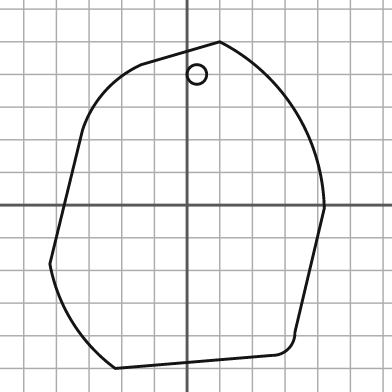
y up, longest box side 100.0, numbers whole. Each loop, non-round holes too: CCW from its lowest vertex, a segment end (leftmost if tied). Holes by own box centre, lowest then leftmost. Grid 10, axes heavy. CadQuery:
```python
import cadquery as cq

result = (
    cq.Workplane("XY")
    .moveTo(-22.0, -50.0)
    .lineTo(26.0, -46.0)
    .threePointArc((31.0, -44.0), (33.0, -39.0))
    .lineTo(42.0, -1.0)
    .threePointArc((33.0, 29.0), (10.0, 50.0))
    .lineTo(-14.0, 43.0)
    .threePointArc((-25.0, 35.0), (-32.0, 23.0))
    .lineTo(-42.0, -18.0)
    .threePointArc((-35.0, -36.0), (-22.0, -50.0))
    .close()
    .moveTo(3.0, 40.0)
    .circle(3.0)
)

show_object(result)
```